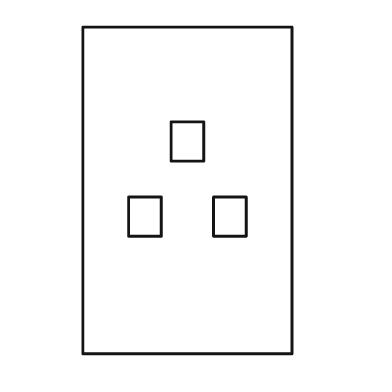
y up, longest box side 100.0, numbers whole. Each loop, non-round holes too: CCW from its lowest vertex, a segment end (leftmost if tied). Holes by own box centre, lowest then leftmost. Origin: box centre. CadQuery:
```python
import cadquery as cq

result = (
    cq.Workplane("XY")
    .moveTo(-32.0, -50.0)
    .lineTo(32.0, -50.0)
    .lineTo(32.0, 50.0)
    .lineTo(-32.0, 50.0)
    .close()
    .moveTo(-18.0, -14.0)
    .lineTo(-8.0, -14.0)
    .lineTo(-8.0, -2.0)
    .lineTo(-18.0, -2.0)
    .close()
    .moveTo(8.0, -14.0)
    .lineTo(18.0, -14.0)
    .lineTo(18.0, -2.0)
    .lineTo(8.0, -2.0)
    .close()
    .moveTo(-5.0, 9.0)
    .lineTo(5.0, 9.0)
    .lineTo(5.0, 21.0)
    .lineTo(-5.0, 21.0)
    .close()
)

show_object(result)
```